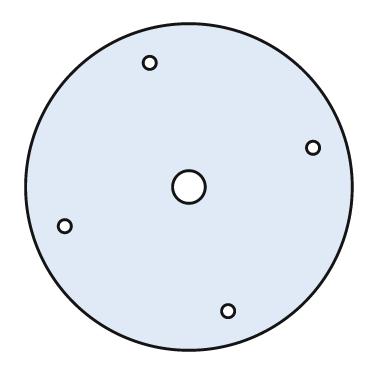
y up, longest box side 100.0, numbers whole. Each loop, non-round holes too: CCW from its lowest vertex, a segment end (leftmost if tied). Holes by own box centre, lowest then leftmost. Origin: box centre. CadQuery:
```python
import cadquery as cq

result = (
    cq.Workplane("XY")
    .moveTo(0.0, 0.0)
    .circle(50.0)
    .moveTo(12.0, -38.0)
    .circle(2.0)
    .moveTo(-38.0, -12.0)
    .circle(2.0)
    .moveTo(0.0, 0.0)
    .circle(5.0)
    .moveTo(38.0, 12.0)
    .circle(2.0)
    .moveTo(-12.0, 38.0)
    .circle(2.0)
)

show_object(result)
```